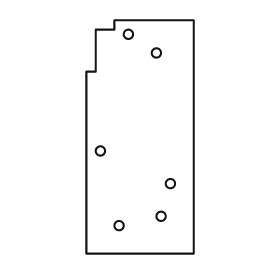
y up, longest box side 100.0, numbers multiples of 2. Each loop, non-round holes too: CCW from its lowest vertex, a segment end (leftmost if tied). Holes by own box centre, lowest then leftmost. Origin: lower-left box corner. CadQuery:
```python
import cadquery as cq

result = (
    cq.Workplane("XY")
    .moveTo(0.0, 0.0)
    .lineTo(46.0, 0.0)
    .lineTo(46.0, 100.0)
    .lineTo(12.0, 100.0)
    .lineTo(12.0, 96.0)
    .lineTo(4.0, 96.0)
    .lineTo(4.0, 78.0)
    .lineTo(0.0, 78.0)
    .close()
    .moveTo(14.0, 12.0)
    .circle(2.0)
    .moveTo(32.0, 16.0)
    .circle(2.0)
    .moveTo(36.0, 30.0)
    .circle(2.0)
    .moveTo(6.0, 44.0)
    .circle(2.0)
    .moveTo(30.0, 86.0)
    .circle(2.0)
    .moveTo(18.0, 94.0)
    .circle(2.0)
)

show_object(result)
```